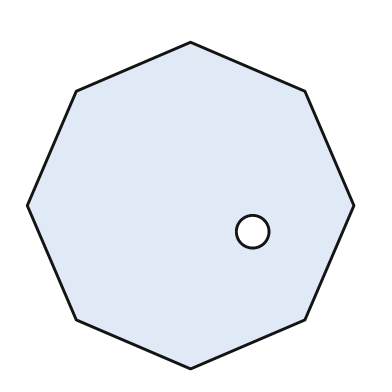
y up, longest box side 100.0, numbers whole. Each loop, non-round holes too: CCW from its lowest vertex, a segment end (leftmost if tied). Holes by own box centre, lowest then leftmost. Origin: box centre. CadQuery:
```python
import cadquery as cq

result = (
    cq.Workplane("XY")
    .moveTo(0.0, -50.0)
    .lineTo(35.0, -35.0)
    .lineTo(50.0, 0.0)
    .lineTo(35.0, 35.0)
    .lineTo(0.0, 50.0)
    .lineTo(-35.0, 35.0)
    .lineTo(-50.0, 0.0)
    .lineTo(-35.0, -35.0)
    .close()
    .moveTo(19.0, -8.0)
    .circle(5.0)
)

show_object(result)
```